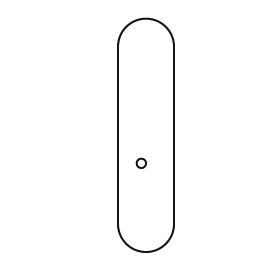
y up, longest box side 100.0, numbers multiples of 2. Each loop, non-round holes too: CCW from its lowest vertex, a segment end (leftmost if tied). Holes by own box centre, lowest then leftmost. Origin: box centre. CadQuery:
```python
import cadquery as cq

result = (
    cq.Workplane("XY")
    .moveTo(-12.0, -38.0)
    .threePointArc((0.0, -50.0), (12.0, -38.0))
    .lineTo(12.0, 38.0)
    .threePointArc((0.0, 50.0), (-12.0, 38.0))
    .close()
    .moveTo(-2.0, -12.0)
    .circle(2.0)
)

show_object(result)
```